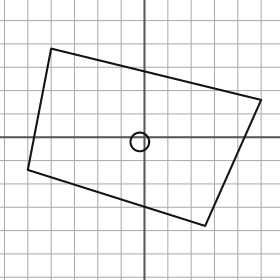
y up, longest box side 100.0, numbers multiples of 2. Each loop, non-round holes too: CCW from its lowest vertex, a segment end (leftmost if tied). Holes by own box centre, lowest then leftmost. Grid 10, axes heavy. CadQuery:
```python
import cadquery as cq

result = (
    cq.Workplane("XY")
    .moveTo(26.0, -38.0)
    .lineTo(50.0, 16.0)
    .lineTo(-40.0, 38.0)
    .lineTo(-50.0, -14.0)
    .close()
    .moveTo(-2.0, -2.0)
    .circle(4.0)
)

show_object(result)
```